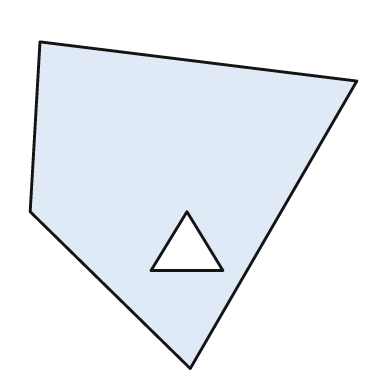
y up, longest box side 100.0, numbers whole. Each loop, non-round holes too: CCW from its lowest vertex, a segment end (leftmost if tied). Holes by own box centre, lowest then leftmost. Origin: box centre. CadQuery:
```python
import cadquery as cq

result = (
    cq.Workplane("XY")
    .moveTo(-1.0, -50.0)
    .lineTo(50.0, 38.0)
    .lineTo(-47.0, 50.0)
    .lineTo(-50.0, -2.0)
    .close()
    .moveTo(-13.0, -20.0)
    .lineTo(9.0, -20.0)
    .lineTo(-2.0, -2.0)
    .close()
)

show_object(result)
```